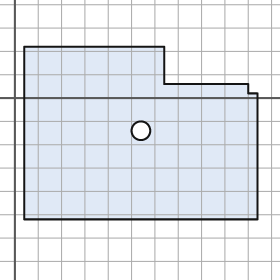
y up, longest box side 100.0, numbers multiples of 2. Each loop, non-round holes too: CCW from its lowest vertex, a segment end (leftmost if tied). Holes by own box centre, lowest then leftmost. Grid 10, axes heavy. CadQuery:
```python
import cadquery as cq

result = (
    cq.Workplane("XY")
    .moveTo(4.0, -52.0)
    .lineTo(104.0, -52.0)
    .lineTo(104.0, 2.0)
    .lineTo(100.0, 2.0)
    .lineTo(100.0, 6.0)
    .lineTo(64.0, 6.0)
    .lineTo(64.0, 22.0)
    .lineTo(4.0, 22.0)
    .close()
    .moveTo(54.0, -14.0)
    .circle(4.0)
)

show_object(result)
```